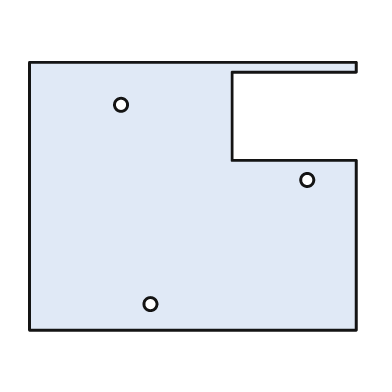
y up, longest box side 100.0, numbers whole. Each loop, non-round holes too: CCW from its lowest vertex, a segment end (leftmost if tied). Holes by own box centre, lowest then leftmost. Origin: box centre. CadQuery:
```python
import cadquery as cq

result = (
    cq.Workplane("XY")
    .moveTo(-50.0, -41.0)
    .lineTo(50.0, -41.0)
    .lineTo(50.0, 11.0)
    .lineTo(12.0, 11.0)
    .lineTo(12.0, 38.0)
    .lineTo(50.0, 38.0)
    .lineTo(50.0, 41.0)
    .lineTo(-50.0, 41.0)
    .close()
    .moveTo(-13.0, -33.0)
    .circle(2.0)
    .moveTo(35.0, 5.0)
    .circle(2.0)
    .moveTo(-22.0, 28.0)
    .circle(2.0)
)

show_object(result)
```